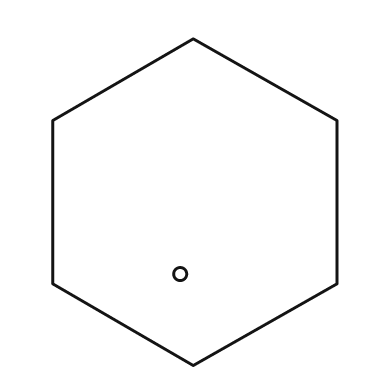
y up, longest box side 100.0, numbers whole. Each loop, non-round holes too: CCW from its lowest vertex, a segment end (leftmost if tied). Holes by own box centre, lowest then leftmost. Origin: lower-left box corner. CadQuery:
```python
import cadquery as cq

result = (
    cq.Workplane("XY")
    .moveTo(43.0, 0.0)
    .lineTo(87.0, 25.0)
    .lineTo(87.0, 75.0)
    .lineTo(43.0, 100.0)
    .lineTo(0.0, 75.0)
    .lineTo(0.0, 25.0)
    .close()
    .moveTo(39.0, 28.0)
    .circle(2.0)
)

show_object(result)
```